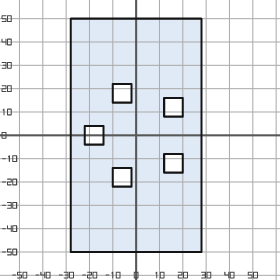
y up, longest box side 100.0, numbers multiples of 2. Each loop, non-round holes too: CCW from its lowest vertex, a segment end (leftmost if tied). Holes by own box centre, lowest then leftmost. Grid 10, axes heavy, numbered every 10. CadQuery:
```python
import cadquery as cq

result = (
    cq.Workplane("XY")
    .moveTo(-28.0, -50.0)
    .lineTo(28.0, -50.0)
    .lineTo(28.0, 50.0)
    .lineTo(-28.0, 50.0)
    .close()
    .moveTo(-10.0, -22.0)
    .lineTo(-2.0, -22.0)
    .lineTo(-2.0, -14.0)
    .lineTo(-10.0, -14.0)
    .close()
    .moveTo(12.0, -16.0)
    .lineTo(20.0, -16.0)
    .lineTo(20.0, -8.0)
    .lineTo(12.0, -8.0)
    .close()
    .moveTo(-22.0, -4.0)
    .lineTo(-14.0, -4.0)
    .lineTo(-14.0, 4.0)
    .lineTo(-22.0, 4.0)
    .close()
    .moveTo(12.0, 8.0)
    .lineTo(20.0, 8.0)
    .lineTo(20.0, 16.0)
    .lineTo(12.0, 16.0)
    .close()
    .moveTo(-10.0, 14.0)
    .lineTo(-2.0, 14.0)
    .lineTo(-2.0, 22.0)
    .lineTo(-10.0, 22.0)
    .close()
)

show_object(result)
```